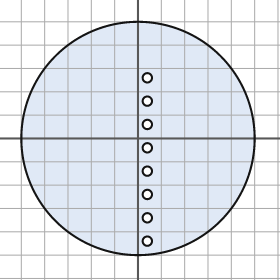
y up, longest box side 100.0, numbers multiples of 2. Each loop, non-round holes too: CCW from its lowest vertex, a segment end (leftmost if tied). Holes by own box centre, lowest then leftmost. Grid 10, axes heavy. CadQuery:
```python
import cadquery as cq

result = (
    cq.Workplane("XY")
    .moveTo(0.0, 0.0)
    .circle(50.0)
    .moveTo(4.0, -44.0)
    .circle(2.0)
    .moveTo(4.0, -34.0)
    .circle(2.0)
    .moveTo(4.0, -24.0)
    .circle(2.0)
    .moveTo(4.0, -14.0)
    .circle(2.0)
    .moveTo(4.0, -4.0)
    .circle(2.0)
    .moveTo(4.0, 6.0)
    .circle(2.0)
    .moveTo(4.0, 16.0)
    .circle(2.0)
    .moveTo(4.0, 26.0)
    .circle(2.0)
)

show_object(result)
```